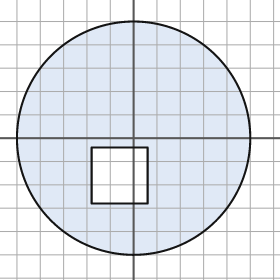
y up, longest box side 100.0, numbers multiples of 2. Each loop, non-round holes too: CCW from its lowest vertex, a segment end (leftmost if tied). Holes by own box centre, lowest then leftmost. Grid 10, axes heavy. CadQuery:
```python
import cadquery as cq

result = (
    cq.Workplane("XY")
    .moveTo(0.0, 0.0)
    .circle(50.0)
    .moveTo(-18.0, -28.0)
    .lineTo(6.0, -28.0)
    .lineTo(6.0, -4.0)
    .lineTo(-18.0, -4.0)
    .close()
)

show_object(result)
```